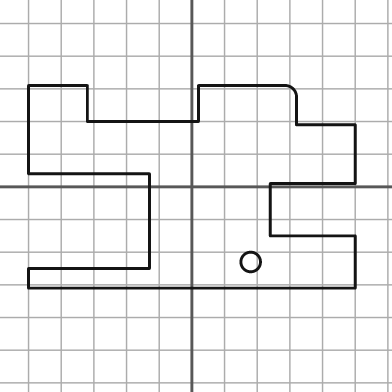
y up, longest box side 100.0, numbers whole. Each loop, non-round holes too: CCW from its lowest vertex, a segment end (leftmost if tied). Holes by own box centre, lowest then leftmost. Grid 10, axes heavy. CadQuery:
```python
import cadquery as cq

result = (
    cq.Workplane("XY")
    .moveTo(-50.0, -31.0)
    .lineTo(50.0, -31.0)
    .lineTo(50.0, -15.0)
    .lineTo(24.0, -15.0)
    .lineTo(24.0, 1.0)
    .lineTo(50.0, 1.0)
    .lineTo(50.0, 19.0)
    .lineTo(32.0, 19.0)
    .lineTo(32.0, 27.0)
    .threePointArc((31.0, 30.0), (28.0, 31.0))
    .lineTo(2.0, 31.0)
    .lineTo(2.0, 20.0)
    .lineTo(-32.0, 20.0)
    .lineTo(-32.0, 31.0)
    .lineTo(-50.0, 31.0)
    .lineTo(-50.0, 4.0)
    .lineTo(-13.0, 4.0)
    .lineTo(-13.0, -25.0)
    .lineTo(-50.0, -25.0)
    .close()
    .moveTo(18.0, -23.0)
    .circle(3.0)
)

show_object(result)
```